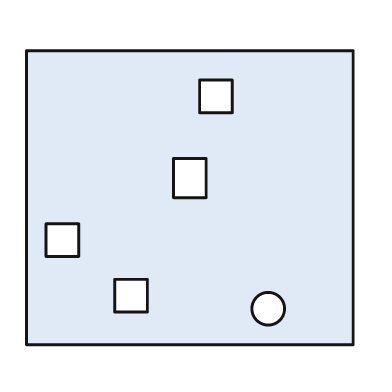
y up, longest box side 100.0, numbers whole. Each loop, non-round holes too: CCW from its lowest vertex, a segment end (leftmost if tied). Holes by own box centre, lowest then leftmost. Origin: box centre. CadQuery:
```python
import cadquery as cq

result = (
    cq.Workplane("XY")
    .moveTo(-50.0, -45.0)
    .lineTo(50.0, -45.0)
    .lineTo(50.0, 45.0)
    .lineTo(-50.0, 45.0)
    .close()
    .moveTo(24.0, -34.0)
    .circle(5.0)
    .moveTo(-23.0, -35.0)
    .lineTo(-13.0, -35.0)
    .lineTo(-13.0, -25.0)
    .lineTo(-23.0, -25.0)
    .close()
    .moveTo(-44.0, -18.0)
    .lineTo(-34.0, -18.0)
    .lineTo(-34.0, -8.0)
    .lineTo(-44.0, -8.0)
    .close()
    .moveTo(-5.0, 0.0)
    .lineTo(5.0, 0.0)
    .lineTo(5.0, 12.0)
    .lineTo(-5.0, 12.0)
    .close()
    .moveTo(3.0, 26.0)
    .lineTo(13.0, 26.0)
    .lineTo(13.0, 36.0)
    .lineTo(3.0, 36.0)
    .close()
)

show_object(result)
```